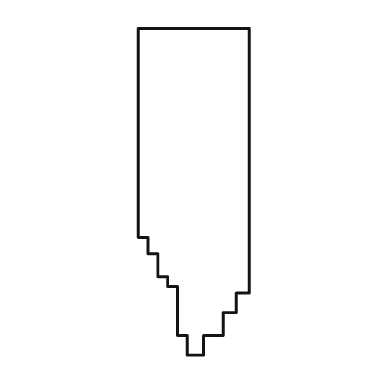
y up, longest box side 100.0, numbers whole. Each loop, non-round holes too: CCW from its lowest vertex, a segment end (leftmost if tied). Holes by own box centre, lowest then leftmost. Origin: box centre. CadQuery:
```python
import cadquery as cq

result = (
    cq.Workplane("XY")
    .moveTo(-2.0, -50.0)
    .lineTo(3.0, -50.0)
    .lineTo(3.0, -44.0)
    .lineTo(9.0, -44.0)
    .lineTo(9.0, -37.0)
    .lineTo(13.0, -37.0)
    .lineTo(13.0, -31.0)
    .lineTo(17.0, -31.0)
    .lineTo(17.0, 50.0)
    .lineTo(-17.0, 50.0)
    .lineTo(-17.0, -14.0)
    .lineTo(-14.0, -14.0)
    .lineTo(-14.0, -19.0)
    .lineTo(-11.0, -19.0)
    .lineTo(-11.0, -26.0)
    .lineTo(-8.0, -26.0)
    .lineTo(-8.0, -29.0)
    .lineTo(-5.0, -29.0)
    .lineTo(-5.0, -44.0)
    .lineTo(-2.0, -44.0)
    .close()
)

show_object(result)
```